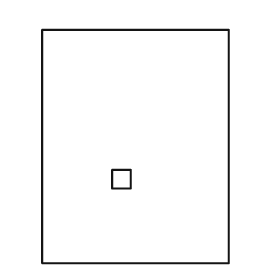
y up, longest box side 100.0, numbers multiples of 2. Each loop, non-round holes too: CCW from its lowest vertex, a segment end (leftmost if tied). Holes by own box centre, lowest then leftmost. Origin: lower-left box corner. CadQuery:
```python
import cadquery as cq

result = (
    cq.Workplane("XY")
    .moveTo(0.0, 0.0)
    .lineTo(80.0, 0.0)
    .lineTo(80.0, 100.0)
    .lineTo(0.0, 100.0)
    .close()
    .moveTo(30.0, 32.0)
    .lineTo(38.0, 32.0)
    .lineTo(38.0, 40.0)
    .lineTo(30.0, 40.0)
    .close()
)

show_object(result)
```